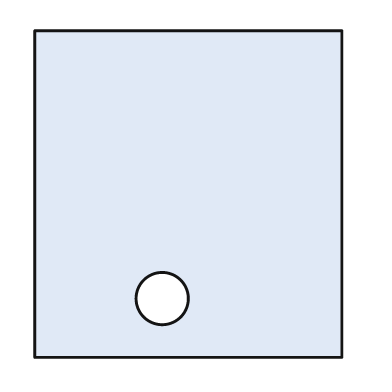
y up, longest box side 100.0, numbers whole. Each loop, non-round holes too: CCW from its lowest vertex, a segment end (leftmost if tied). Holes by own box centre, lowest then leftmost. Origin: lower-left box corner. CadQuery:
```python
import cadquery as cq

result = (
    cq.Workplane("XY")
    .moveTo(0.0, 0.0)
    .lineTo(94.0, 0.0)
    .lineTo(94.0, 100.0)
    .lineTo(0.0, 100.0)
    .close()
    .moveTo(39.0, 18.0)
    .circle(8.0)
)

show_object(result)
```